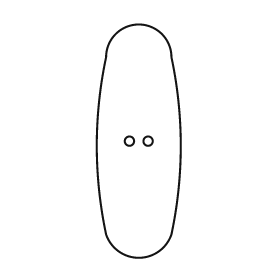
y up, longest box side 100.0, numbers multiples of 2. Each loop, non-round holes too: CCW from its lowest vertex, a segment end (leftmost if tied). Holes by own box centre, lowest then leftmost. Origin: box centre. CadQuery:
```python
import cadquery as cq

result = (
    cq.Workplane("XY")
    .moveTo(-14.0, -40.0)
    .threePointArc((0.0, -50.0), (14.0, -40.0))
    .threePointArc((18.0, -2.0), (14.0, 36.0))
    .threePointArc((0.0, 50.0), (-14.0, 36.0))
    .threePointArc((-18.0, -2.0), (-14.0, -40.0))
    .close()
    .moveTo(-4.0, 0.0)
    .circle(2.0)
    .moveTo(4.0, 0.0)
    .circle(2.0)
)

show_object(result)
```